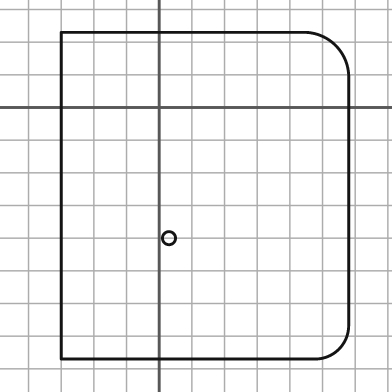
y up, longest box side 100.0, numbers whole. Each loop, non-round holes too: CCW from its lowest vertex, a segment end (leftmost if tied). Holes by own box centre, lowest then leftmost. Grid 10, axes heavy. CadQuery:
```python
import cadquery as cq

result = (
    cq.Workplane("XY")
    .moveTo(-30.0, -77.0)
    .lineTo(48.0, -77.0)
    .threePointArc((55.0, -74.0), (58.0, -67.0))
    .lineTo(58.0, 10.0)
    .threePointArc((54.0, 19.0), (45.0, 23.0))
    .lineTo(-30.0, 23.0)
    .close()
    .moveTo(3.0, -40.0)
    .circle(2.0)
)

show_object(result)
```